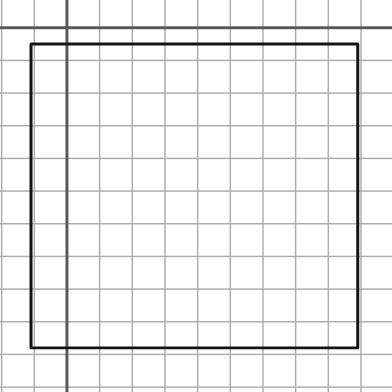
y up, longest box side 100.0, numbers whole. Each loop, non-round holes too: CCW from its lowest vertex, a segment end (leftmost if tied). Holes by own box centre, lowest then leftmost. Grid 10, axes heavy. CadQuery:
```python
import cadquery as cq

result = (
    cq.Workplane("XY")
    .moveTo(-11.0, -98.0)
    .lineTo(89.0, -98.0)
    .lineTo(89.0, -5.0)
    .lineTo(-11.0, -5.0)
    .close()
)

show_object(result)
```